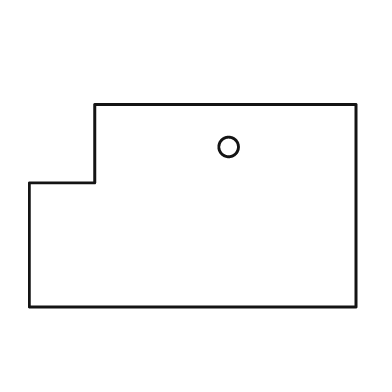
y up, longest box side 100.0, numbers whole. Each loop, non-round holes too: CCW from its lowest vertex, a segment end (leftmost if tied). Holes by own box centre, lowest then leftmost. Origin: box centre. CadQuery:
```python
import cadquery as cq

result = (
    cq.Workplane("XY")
    .moveTo(-50.0, -31.0)
    .lineTo(50.0, -31.0)
    .lineTo(50.0, 31.0)
    .lineTo(-30.0, 31.0)
    .lineTo(-30.0, 7.0)
    .lineTo(-50.0, 7.0)
    .close()
    .moveTo(11.0, 18.0)
    .circle(3.0)
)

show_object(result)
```